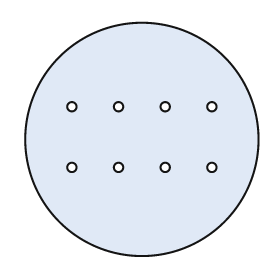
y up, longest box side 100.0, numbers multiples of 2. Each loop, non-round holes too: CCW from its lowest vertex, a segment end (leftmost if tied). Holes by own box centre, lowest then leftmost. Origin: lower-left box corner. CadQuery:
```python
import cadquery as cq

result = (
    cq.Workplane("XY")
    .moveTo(50.0, 50.0)
    .circle(50.0)
    .moveTo(20.0, 38.0)
    .circle(2.0)
    .moveTo(40.0, 38.0)
    .circle(2.0)
    .moveTo(60.0, 38.0)
    .circle(2.0)
    .moveTo(80.0, 38.0)
    .circle(2.0)
    .moveTo(20.0, 64.0)
    .circle(2.0)
    .moveTo(40.0, 64.0)
    .circle(2.0)
    .moveTo(60.0, 64.0)
    .circle(2.0)
    .moveTo(80.0, 64.0)
    .circle(2.0)
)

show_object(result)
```